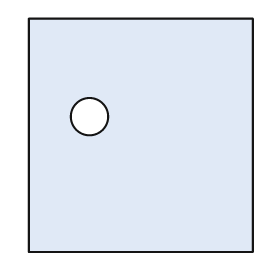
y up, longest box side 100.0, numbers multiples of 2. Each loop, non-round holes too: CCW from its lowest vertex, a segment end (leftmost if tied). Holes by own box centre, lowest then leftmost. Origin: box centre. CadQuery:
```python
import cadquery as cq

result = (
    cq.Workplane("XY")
    .moveTo(-48.0, -50.0)
    .lineTo(48.0, -50.0)
    .lineTo(48.0, 50.0)
    .lineTo(-48.0, 50.0)
    .close()
    .moveTo(-22.0, 8.0)
    .circle(8.0)
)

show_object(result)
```